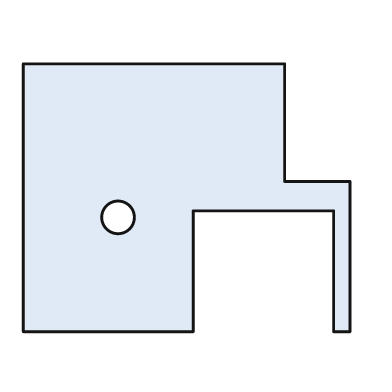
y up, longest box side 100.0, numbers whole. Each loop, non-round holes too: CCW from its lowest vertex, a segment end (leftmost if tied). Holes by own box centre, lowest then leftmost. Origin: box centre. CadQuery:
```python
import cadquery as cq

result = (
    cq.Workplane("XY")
    .moveTo(-50.0, -41.0)
    .lineTo(2.0, -41.0)
    .lineTo(2.0, -4.0)
    .lineTo(45.0, -4.0)
    .lineTo(45.0, -41.0)
    .lineTo(50.0, -41.0)
    .lineTo(50.0, 5.0)
    .lineTo(30.0, 5.0)
    .lineTo(30.0, 41.0)
    .lineTo(-50.0, 41.0)
    .close()
    .moveTo(-21.0, -6.0)
    .circle(5.0)
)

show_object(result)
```